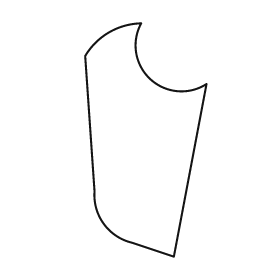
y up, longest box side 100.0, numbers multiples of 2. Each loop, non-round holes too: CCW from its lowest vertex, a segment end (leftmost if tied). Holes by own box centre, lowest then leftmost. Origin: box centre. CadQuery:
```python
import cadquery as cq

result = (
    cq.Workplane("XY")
    .moveTo(12.0, -50.0)
    .lineTo(26.0, 24.0)
    .threePointArc((2.0, 26.0), (-2.0, 50.0))
    .threePointArc((-16.0, 46.0), (-26.0, 36.0))
    .lineTo(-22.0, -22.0)
    .threePointArc((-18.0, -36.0), (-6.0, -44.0))
    .close()
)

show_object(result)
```